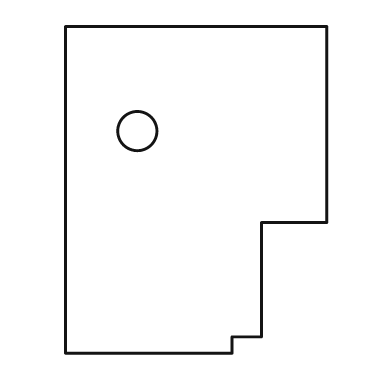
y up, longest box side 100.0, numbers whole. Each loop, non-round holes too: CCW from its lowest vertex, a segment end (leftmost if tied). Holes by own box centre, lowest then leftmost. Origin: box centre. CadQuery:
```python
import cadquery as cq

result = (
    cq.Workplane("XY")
    .moveTo(-40.0, -50.0)
    .lineTo(11.0, -50.0)
    .lineTo(11.0, -45.0)
    .lineTo(20.0, -45.0)
    .lineTo(20.0, -10.0)
    .lineTo(40.0, -10.0)
    .lineTo(40.0, 50.0)
    .lineTo(-40.0, 50.0)
    .close()
    .moveTo(-18.0, 18.0)
    .circle(6.0)
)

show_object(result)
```